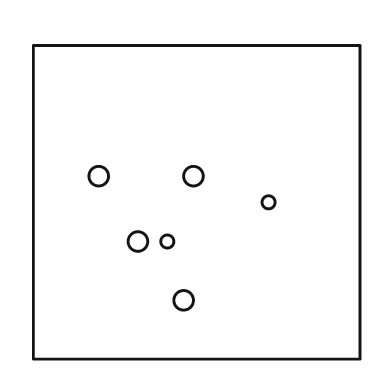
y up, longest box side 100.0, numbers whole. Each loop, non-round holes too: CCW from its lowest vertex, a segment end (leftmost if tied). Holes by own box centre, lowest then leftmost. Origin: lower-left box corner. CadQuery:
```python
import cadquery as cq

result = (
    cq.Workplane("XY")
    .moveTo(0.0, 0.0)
    .lineTo(100.0, 0.0)
    .lineTo(100.0, 96.0)
    .lineTo(0.0, 96.0)
    .close()
    .moveTo(46.0, 18.0)
    .circle(3.0)
    .moveTo(32.0, 36.0)
    .circle(3.0)
    .moveTo(41.0, 36.0)
    .circle(2.0)
    .moveTo(72.0, 48.0)
    .circle(2.0)
    .moveTo(20.0, 56.0)
    .circle(3.0)
    .moveTo(49.0, 56.0)
    .circle(3.0)
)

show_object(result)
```